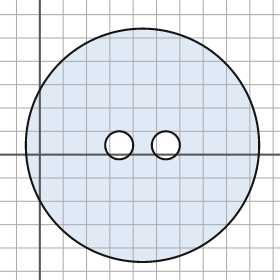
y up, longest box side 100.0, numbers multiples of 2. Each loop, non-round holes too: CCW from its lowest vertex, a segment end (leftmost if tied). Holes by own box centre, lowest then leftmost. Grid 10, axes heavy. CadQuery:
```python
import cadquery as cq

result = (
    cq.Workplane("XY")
    .moveTo(44.0, 4.0)
    .circle(50.0)
    .moveTo(34.0, 4.0)
    .circle(6.0)
    .moveTo(54.0, 4.0)
    .circle(6.0)
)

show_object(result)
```